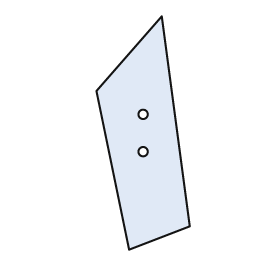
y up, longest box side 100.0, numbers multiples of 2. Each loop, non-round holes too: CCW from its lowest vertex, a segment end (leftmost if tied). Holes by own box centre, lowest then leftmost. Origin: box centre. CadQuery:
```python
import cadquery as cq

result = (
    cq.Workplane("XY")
    .moveTo(-6.0, -50.0)
    .lineTo(20.0, -40.0)
    .lineTo(8.0, 50.0)
    .lineTo(-20.0, 18.0)
    .close()
    .moveTo(0.0, -8.0)
    .circle(2.0)
    .moveTo(0.0, 8.0)
    .circle(2.0)
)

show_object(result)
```